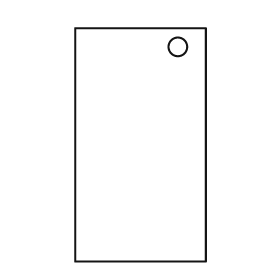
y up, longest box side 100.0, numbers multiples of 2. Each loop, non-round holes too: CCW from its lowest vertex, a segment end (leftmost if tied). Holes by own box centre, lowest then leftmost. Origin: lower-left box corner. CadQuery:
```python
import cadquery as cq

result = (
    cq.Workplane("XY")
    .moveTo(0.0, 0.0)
    .lineTo(56.0, 0.0)
    .lineTo(56.0, 100.0)
    .lineTo(0.0, 100.0)
    .close()
    .moveTo(44.0, 92.0)
    .circle(4.0)
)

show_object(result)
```